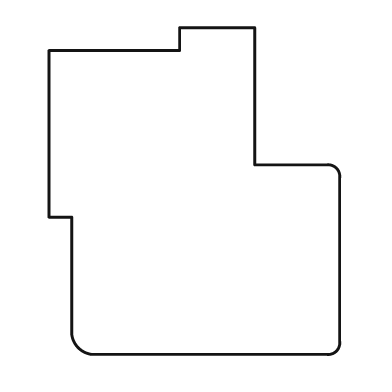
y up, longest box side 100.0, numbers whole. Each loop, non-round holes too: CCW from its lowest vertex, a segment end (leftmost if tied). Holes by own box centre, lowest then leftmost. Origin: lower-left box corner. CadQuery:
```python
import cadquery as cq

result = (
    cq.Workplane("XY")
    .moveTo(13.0, 0.0)
    .lineTo(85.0, 0.0)
    .threePointArc((88.0, 1.0), (89.0, 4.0))
    .lineTo(89.0, 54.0)
    .threePointArc((88.0, 57.0), (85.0, 58.0))
    .lineTo(63.0, 58.0)
    .lineTo(63.0, 100.0)
    .lineTo(40.0, 100.0)
    .lineTo(40.0, 93.0)
    .lineTo(0.0, 93.0)
    .lineTo(0.0, 42.0)
    .lineTo(7.0, 42.0)
    .lineTo(7.0, 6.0)
    .threePointArc((9.0, 2.0), (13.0, 0.0))
    .close()
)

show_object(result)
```